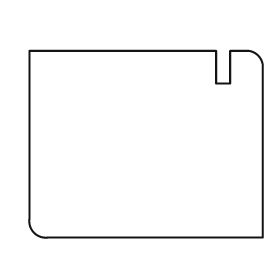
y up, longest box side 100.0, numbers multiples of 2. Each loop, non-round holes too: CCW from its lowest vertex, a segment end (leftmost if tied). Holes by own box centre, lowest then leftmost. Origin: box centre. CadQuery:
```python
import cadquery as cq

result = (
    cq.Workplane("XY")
    .moveTo(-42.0, -40.0)
    .lineTo(50.0, -40.0)
    .lineTo(50.0, 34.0)
    .threePointArc((48.0, 38.0), (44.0, 40.0))
    .lineTo(36.0, 40.0)
    .lineTo(36.0, 26.0)
    .lineTo(30.0, 26.0)
    .lineTo(30.0, 40.0)
    .lineTo(-50.0, 40.0)
    .lineTo(-50.0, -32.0)
    .threePointArc((-48.0, -38.0), (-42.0, -40.0))
    .close()
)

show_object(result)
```